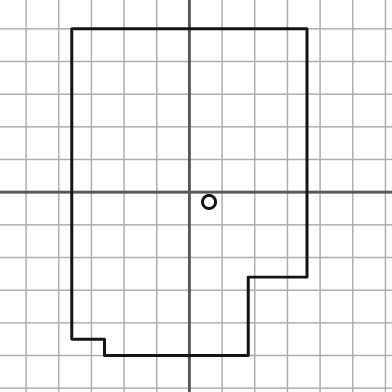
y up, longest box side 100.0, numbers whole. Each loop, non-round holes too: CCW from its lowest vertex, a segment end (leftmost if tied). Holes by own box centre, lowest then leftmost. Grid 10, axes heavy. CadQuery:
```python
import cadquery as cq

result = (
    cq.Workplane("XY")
    .moveTo(-26.0, -50.0)
    .lineTo(18.0, -50.0)
    .lineTo(18.0, -26.0)
    .lineTo(36.0, -26.0)
    .lineTo(36.0, 50.0)
    .lineTo(-36.0, 50.0)
    .lineTo(-36.0, -45.0)
    .lineTo(-26.0, -45.0)
    .close()
    .moveTo(6.0, -3.0)
    .circle(2.0)
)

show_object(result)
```